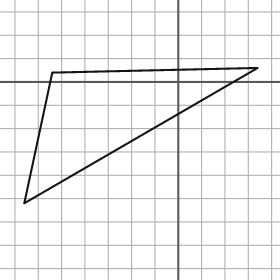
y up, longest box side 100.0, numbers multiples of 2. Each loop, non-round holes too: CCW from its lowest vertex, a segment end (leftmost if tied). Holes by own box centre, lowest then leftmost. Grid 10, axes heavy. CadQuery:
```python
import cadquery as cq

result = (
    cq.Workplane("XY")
    .moveTo(-66.0, -52.0)
    .lineTo(34.0, 6.0)
    .lineTo(-54.0, 4.0)
    .close()
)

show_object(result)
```